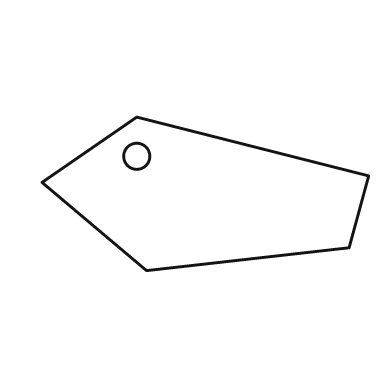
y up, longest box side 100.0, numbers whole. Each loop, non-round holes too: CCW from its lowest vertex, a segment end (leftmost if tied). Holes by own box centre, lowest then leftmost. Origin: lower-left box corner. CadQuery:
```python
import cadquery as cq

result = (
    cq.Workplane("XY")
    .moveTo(32.0, 0.0)
    .lineTo(94.0, 7.0)
    .lineTo(100.0, 29.0)
    .lineTo(29.0, 47.0)
    .lineTo(0.0, 27.0)
    .close()
    .moveTo(29.0, 35.0)
    .circle(4.0)
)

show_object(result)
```